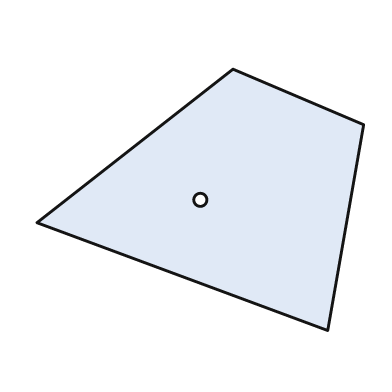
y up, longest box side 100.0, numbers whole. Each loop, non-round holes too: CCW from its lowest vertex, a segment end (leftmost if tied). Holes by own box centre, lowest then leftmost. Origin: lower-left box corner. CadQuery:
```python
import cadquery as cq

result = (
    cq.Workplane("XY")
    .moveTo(89.0, 0.0)
    .lineTo(100.0, 63.0)
    .lineTo(60.0, 80.0)
    .lineTo(0.0, 33.0)
    .close()
    .moveTo(50.0, 40.0)
    .circle(2.0)
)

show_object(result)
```